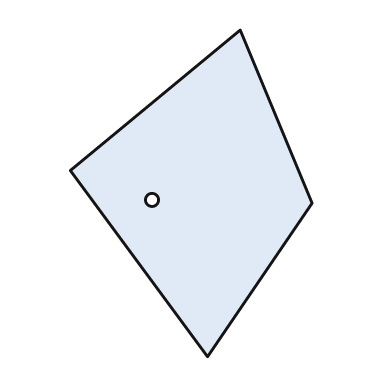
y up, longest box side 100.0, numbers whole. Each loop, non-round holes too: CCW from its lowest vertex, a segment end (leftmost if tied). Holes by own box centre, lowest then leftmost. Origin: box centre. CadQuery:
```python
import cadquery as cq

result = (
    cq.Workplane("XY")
    .moveTo(5.0, -50.0)
    .lineTo(37.0, -3.0)
    .lineTo(15.0, 50.0)
    .lineTo(-37.0, 7.0)
    .close()
    .moveTo(-12.0, -2.0)
    .circle(2.0)
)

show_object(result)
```